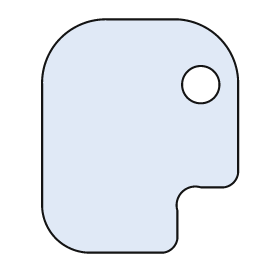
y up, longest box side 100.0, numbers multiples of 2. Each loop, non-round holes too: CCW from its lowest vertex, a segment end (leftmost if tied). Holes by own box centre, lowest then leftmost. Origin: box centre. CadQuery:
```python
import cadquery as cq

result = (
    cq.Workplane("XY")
    .moveTo(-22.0, -50.0)
    .lineTo(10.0, -50.0)
    .threePointArc((14.0, -48.0), (16.0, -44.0))
    .lineTo(16.0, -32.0)
    .threePointArc((18.0, -24.0), (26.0, -22.0))
    .lineTo(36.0, -22.0)
    .threePointArc((40.0, -20.0), (42.0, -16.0))
    .lineTo(42.0, 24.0)
    .threePointArc((34.0, 42.0), (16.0, 50.0))
    .lineTo(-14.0, 50.0)
    .threePointArc((-34.0, 42.0), (-42.0, 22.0))
    .lineTo(-42.0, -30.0)
    .threePointArc((-36.0, -44.0), (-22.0, -50.0))
    .close()
    .moveTo(26.0, 22.0)
    .circle(8.0)
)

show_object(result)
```